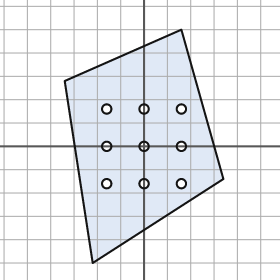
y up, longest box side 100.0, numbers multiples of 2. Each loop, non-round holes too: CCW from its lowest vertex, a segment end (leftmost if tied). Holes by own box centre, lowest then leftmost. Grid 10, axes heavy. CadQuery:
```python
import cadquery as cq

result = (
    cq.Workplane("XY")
    .moveTo(-22.0, -50.0)
    .lineTo(34.0, -14.0)
    .lineTo(16.0, 50.0)
    .lineTo(-34.0, 28.0)
    .close()
    .moveTo(-16.0, -16.0)
    .circle(2.0)
    .moveTo(0.0, -16.0)
    .circle(2.0)
    .moveTo(16.0, -16.0)
    .circle(2.0)
    .moveTo(-16.0, 0.0)
    .circle(2.0)
    .moveTo(0.0, 0.0)
    .circle(2.0)
    .moveTo(16.0, 0.0)
    .circle(2.0)
    .moveTo(-16.0, 16.0)
    .circle(2.0)
    .moveTo(0.0, 16.0)
    .circle(2.0)
    .moveTo(16.0, 16.0)
    .circle(2.0)
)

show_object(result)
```